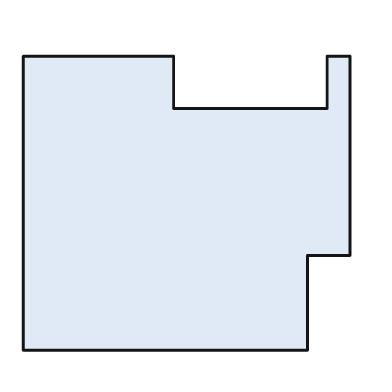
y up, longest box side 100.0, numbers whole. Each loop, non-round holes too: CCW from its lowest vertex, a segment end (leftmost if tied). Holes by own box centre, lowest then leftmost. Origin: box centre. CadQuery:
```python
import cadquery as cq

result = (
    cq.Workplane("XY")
    .moveTo(-50.0, -45.0)
    .lineTo(37.0, -45.0)
    .lineTo(37.0, -16.0)
    .lineTo(50.0, -16.0)
    .lineTo(50.0, 45.0)
    .lineTo(43.0, 45.0)
    .lineTo(43.0, 29.0)
    .lineTo(-4.0, 29.0)
    .lineTo(-4.0, 45.0)
    .lineTo(-50.0, 45.0)
    .close()
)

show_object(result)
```